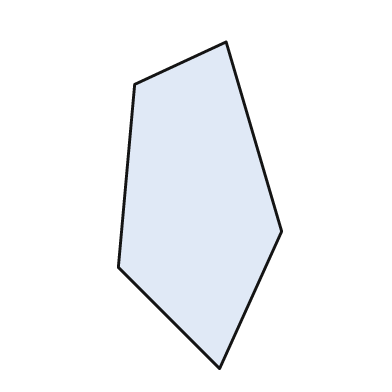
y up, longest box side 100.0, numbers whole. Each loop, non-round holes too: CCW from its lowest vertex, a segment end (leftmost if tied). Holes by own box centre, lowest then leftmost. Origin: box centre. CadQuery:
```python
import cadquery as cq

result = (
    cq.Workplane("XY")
    .moveTo(6.0, -50.0)
    .lineTo(25.0, -8.0)
    .lineTo(8.0, 50.0)
    .lineTo(-20.0, 37.0)
    .lineTo(-25.0, -19.0)
    .close()
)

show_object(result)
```